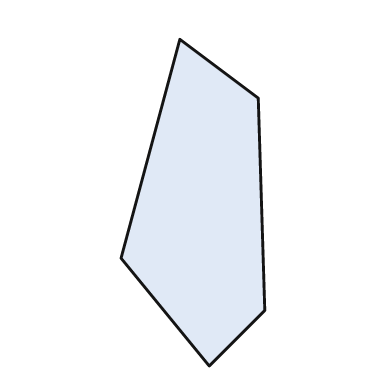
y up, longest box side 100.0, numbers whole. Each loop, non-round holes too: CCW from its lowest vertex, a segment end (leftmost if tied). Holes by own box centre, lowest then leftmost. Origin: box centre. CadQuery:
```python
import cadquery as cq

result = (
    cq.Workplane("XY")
    .moveTo(5.0, -50.0)
    .lineTo(22.0, -33.0)
    .lineTo(20.0, 32.0)
    .lineTo(-4.0, 50.0)
    .lineTo(-22.0, -17.0)
    .close()
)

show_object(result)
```